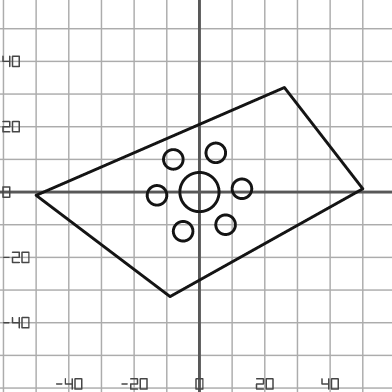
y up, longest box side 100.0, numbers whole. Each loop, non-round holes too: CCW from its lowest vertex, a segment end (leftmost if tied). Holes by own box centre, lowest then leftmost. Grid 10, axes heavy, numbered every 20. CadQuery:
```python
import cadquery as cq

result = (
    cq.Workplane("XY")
    .moveTo(-9.0, -32.0)
    .lineTo(50.0, 1.0)
    .lineTo(26.0, 32.0)
    .lineTo(-50.0, -1.0)
    .close()
    .moveTo(-5.0, -12.0)
    .circle(3.0)
    .moveTo(8.0, -10.0)
    .circle(3.0)
    .moveTo(-13.0, -1.0)
    .circle(3.0)
    .moveTo(0.0, 0.0)
    .circle(6.0)
    .moveTo(13.0, 1.0)
    .circle(3.0)
    .moveTo(-8.0, 10.0)
    .circle(3.0)
    .moveTo(5.0, 12.0)
    .circle(3.0)
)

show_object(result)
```